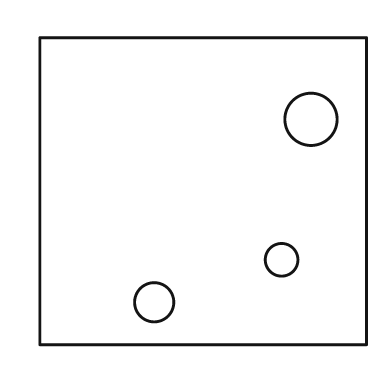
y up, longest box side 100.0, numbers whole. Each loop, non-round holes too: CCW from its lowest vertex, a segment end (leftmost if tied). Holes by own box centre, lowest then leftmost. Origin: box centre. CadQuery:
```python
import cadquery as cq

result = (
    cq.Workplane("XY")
    .moveTo(-50.0, -47.0)
    .lineTo(50.0, -47.0)
    .lineTo(50.0, 47.0)
    .lineTo(-50.0, 47.0)
    .close()
    .moveTo(-15.0, -34.0)
    .circle(6.0)
    .moveTo(24.0, -21.0)
    .circle(5.0)
    .moveTo(33.0, 22.0)
    .circle(8.0)
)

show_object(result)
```